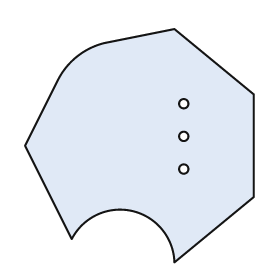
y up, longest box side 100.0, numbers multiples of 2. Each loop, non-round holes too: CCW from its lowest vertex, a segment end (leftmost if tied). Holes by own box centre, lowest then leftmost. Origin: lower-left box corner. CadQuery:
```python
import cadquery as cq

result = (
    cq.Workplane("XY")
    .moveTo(64.0, 0.0)
    .lineTo(98.0, 28.0)
    .lineTo(98.0, 72.0)
    .lineTo(64.0, 100.0)
    .lineTo(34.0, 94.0)
    .threePointArc((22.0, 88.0), (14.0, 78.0))
    .lineTo(0.0, 50.0)
    .lineTo(20.0, 10.0)
    .threePointArc((46.0, 22.0), (64.0, 0.0))
    .close()
    .moveTo(68.0, 40.0)
    .circle(2.0)
    .moveTo(68.0, 54.0)
    .circle(2.0)
    .moveTo(68.0, 68.0)
    .circle(2.0)
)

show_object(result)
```